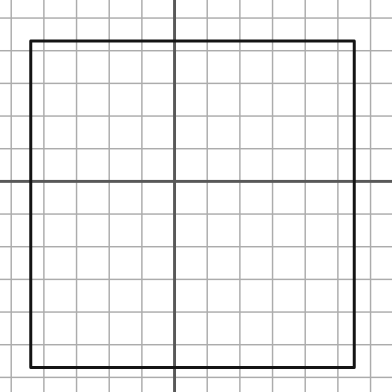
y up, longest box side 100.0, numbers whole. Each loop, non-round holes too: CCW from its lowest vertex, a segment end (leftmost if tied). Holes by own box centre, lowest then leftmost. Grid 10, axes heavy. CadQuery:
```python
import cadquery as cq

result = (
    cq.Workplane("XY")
    .moveTo(-44.0, -57.0)
    .lineTo(55.0, -57.0)
    .lineTo(55.0, 43.0)
    .lineTo(-44.0, 43.0)
    .close()
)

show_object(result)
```